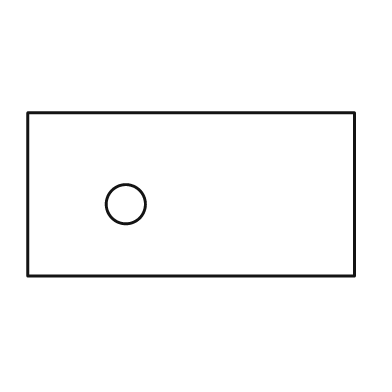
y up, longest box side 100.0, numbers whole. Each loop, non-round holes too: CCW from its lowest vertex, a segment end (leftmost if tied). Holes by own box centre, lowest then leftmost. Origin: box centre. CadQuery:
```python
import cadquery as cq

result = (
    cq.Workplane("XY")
    .moveTo(-50.0, -25.0)
    .lineTo(50.0, -25.0)
    .lineTo(50.0, 25.0)
    .lineTo(-50.0, 25.0)
    .close()
    .moveTo(-20.0, -3.0)
    .circle(6.0)
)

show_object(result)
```